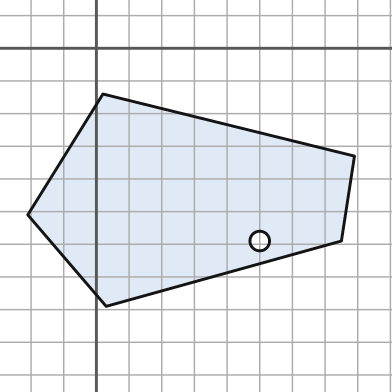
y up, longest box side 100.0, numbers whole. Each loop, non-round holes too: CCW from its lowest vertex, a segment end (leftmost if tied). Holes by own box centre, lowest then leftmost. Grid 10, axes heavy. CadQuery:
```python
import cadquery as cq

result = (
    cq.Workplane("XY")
    .moveTo(3.0, -79.0)
    .lineTo(75.0, -59.0)
    .lineTo(79.0, -33.0)
    .lineTo(2.0, -14.0)
    .lineTo(-21.0, -51.0)
    .close()
    .moveTo(50.0, -59.0)
    .circle(3.0)
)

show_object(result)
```